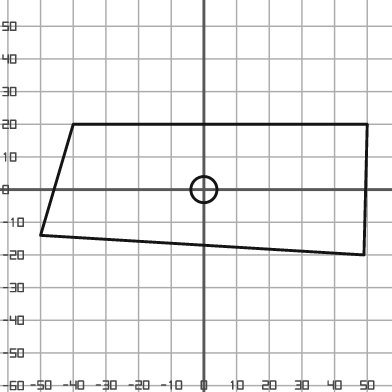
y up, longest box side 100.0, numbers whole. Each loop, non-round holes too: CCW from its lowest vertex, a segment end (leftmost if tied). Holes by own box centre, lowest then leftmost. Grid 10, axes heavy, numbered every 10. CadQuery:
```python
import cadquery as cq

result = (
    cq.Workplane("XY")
    .moveTo(49.0, -20.0)
    .lineTo(50.0, 20.0)
    .lineTo(-40.0, 20.0)
    .lineTo(-50.0, -14.0)
    .close()
    .moveTo(0.0, 0.0)
    .circle(4.0)
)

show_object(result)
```